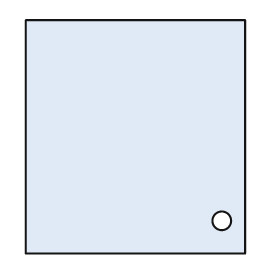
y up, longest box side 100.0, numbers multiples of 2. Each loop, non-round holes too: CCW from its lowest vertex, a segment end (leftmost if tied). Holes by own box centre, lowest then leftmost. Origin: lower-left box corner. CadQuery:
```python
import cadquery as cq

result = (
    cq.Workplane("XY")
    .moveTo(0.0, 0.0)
    .lineTo(94.0, 0.0)
    .lineTo(94.0, 100.0)
    .lineTo(0.0, 100.0)
    .close()
    .moveTo(84.0, 14.0)
    .circle(4.0)
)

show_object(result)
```